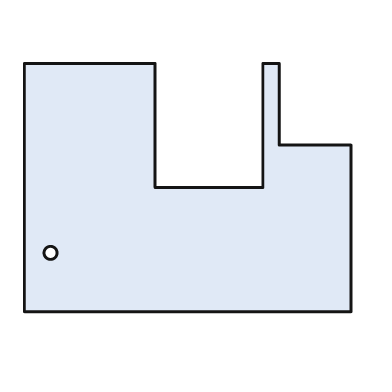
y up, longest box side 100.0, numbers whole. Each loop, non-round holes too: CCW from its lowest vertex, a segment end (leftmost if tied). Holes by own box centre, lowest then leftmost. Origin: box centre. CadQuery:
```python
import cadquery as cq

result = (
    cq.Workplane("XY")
    .moveTo(-50.0, -38.0)
    .lineTo(50.0, -38.0)
    .lineTo(50.0, 13.0)
    .lineTo(28.0, 13.0)
    .lineTo(28.0, 38.0)
    .lineTo(23.0, 38.0)
    .lineTo(23.0, 0.0)
    .lineTo(-10.0, 0.0)
    .lineTo(-10.0, 38.0)
    .lineTo(-50.0, 38.0)
    .close()
    .moveTo(-42.0, -20.0)
    .circle(2.0)
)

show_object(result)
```